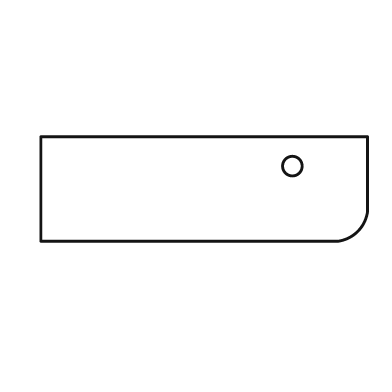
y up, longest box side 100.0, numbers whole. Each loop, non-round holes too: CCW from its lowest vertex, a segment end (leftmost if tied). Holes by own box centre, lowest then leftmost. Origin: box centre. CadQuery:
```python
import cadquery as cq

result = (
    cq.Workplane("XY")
    .moveTo(-50.0, -16.0)
    .lineTo(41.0, -16.0)
    .threePointArc((47.0, -13.0), (50.0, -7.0))
    .lineTo(50.0, 16.0)
    .lineTo(-50.0, 16.0)
    .close()
    .moveTo(27.0, 7.0)
    .circle(3.0)
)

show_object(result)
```